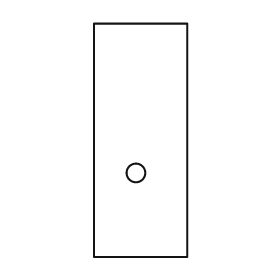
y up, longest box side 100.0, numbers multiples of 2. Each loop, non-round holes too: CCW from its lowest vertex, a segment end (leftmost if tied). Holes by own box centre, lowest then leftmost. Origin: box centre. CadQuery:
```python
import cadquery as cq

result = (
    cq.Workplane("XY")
    .moveTo(-20.0, -50.0)
    .lineTo(20.0, -50.0)
    .lineTo(20.0, 50.0)
    .lineTo(-20.0, 50.0)
    .close()
    .moveTo(-2.0, -14.0)
    .circle(4.0)
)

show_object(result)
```